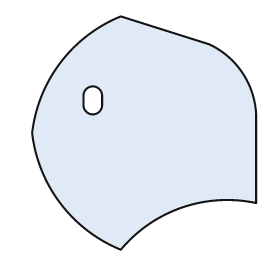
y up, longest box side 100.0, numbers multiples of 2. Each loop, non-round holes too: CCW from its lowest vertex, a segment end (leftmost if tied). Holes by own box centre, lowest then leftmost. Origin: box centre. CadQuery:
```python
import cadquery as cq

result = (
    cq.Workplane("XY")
    .moveTo(-10.0, -50.0)
    .threePointArc((16.0, -32.0), (48.0, -30.0))
    .lineTo(48.0, 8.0)
    .threePointArc((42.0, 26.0), (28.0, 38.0))
    .lineTo(-10.0, 50.0)
    .threePointArc((-36.0, 30.0), (-48.0, 0.0))
    .threePointArc((-36.0, -30.0), (-10.0, -50.0))
    .close()
    .moveTo(-26.0, 12.0)
    .threePointArc((-22.0, 8.0), (-18.0, 12.0))
    .lineTo(-18.0, 16.0)
    .threePointArc((-22.0, 20.0), (-26.0, 16.0))
    .close()
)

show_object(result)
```